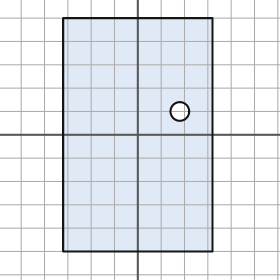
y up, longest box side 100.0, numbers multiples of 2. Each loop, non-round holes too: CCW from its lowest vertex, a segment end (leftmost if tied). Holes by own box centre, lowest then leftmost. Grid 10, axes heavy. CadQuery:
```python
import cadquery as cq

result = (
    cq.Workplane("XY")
    .moveTo(-32.0, -50.0)
    .lineTo(32.0, -50.0)
    .lineTo(32.0, 50.0)
    .lineTo(-32.0, 50.0)
    .close()
    .moveTo(18.0, 10.0)
    .circle(4.0)
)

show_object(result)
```